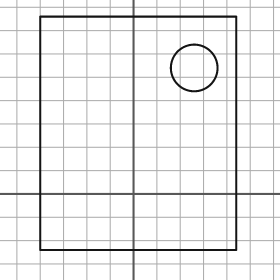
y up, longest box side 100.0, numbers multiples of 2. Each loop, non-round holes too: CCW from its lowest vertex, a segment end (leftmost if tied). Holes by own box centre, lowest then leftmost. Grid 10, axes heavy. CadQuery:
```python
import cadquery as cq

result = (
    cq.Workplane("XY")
    .moveTo(-40.0, -24.0)
    .lineTo(44.0, -24.0)
    .lineTo(44.0, 76.0)
    .lineTo(-40.0, 76.0)
    .close()
    .moveTo(26.0, 54.0)
    .circle(10.0)
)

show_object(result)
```